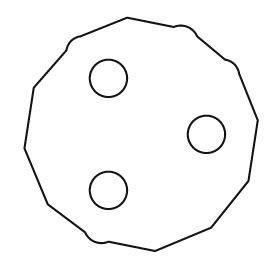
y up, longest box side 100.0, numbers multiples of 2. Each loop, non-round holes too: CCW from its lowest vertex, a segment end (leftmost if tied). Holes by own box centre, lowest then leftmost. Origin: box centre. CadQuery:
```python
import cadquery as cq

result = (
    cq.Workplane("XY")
    .moveTo(6.0, -50.0)
    .lineTo(30.0, -40.0)
    .lineTo(46.0, -20.0)
    .lineTo(50.0, 6.0)
    .lineTo(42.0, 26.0)
    .threePointArc((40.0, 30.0), (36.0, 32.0))
    .lineTo(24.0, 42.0)
    .threePointArc((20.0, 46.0), (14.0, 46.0))
    .lineTo(-6.0, 50.0)
    .lineTo(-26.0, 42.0)
    .threePointArc((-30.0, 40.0), (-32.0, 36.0))
    .lineTo(-46.0, 20.0)
    .lineTo(-50.0, -6.0)
    .lineTo(-40.0, -30.0)
    .lineTo(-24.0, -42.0)
    .threePointArc((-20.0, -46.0), (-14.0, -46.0))
    .close()
    .moveTo(-14.0, -24.0)
    .circle(8.0)
    .moveTo(28.0, 0.0)
    .circle(8.0)
    .moveTo(-14.0, 24.0)
    .circle(8.0)
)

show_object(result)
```